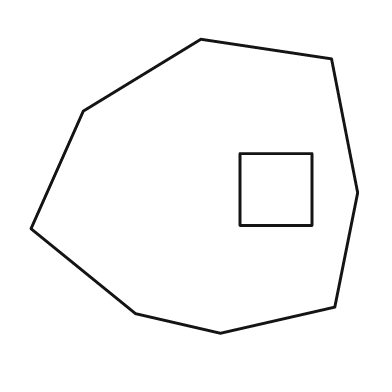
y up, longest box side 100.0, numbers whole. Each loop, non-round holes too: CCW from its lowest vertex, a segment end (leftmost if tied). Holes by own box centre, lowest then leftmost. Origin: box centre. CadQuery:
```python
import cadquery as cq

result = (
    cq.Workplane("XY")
    .moveTo(8.0, -45.0)
    .lineTo(43.0, -37.0)
    .lineTo(50.0, -2.0)
    .lineTo(42.0, 39.0)
    .lineTo(2.0, 45.0)
    .lineTo(-34.0, 23.0)
    .lineTo(-50.0, -13.0)
    .lineTo(-18.0, -39.0)
    .close()
    .moveTo(14.0, -12.0)
    .lineTo(36.0, -12.0)
    .lineTo(36.0, 10.0)
    .lineTo(14.0, 10.0)
    .close()
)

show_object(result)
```